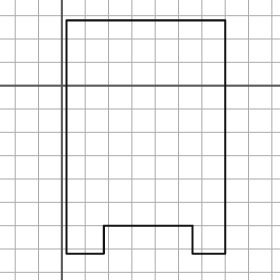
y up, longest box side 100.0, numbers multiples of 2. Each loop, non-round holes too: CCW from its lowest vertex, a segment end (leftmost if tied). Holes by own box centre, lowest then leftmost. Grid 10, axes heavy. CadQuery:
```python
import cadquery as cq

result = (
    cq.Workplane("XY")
    .moveTo(2.0, -72.0)
    .lineTo(18.0, -72.0)
    .lineTo(18.0, -60.0)
    .lineTo(56.0, -60.0)
    .lineTo(56.0, -72.0)
    .lineTo(70.0, -72.0)
    .lineTo(70.0, 28.0)
    .lineTo(2.0, 28.0)
    .close()
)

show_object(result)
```